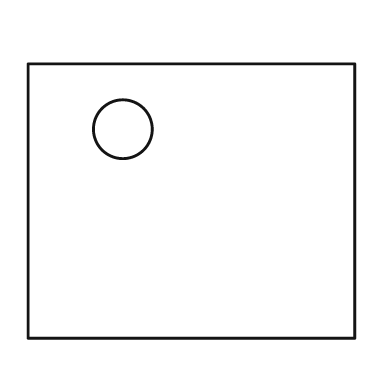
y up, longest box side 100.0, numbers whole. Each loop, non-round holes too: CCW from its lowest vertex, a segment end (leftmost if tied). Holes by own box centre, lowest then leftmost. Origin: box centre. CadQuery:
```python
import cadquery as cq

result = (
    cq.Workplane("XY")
    .moveTo(-50.0, -42.0)
    .lineTo(50.0, -42.0)
    .lineTo(50.0, 42.0)
    .lineTo(-50.0, 42.0)
    .close()
    .moveTo(-21.0, 22.0)
    .circle(9.0)
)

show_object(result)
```